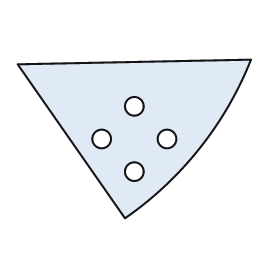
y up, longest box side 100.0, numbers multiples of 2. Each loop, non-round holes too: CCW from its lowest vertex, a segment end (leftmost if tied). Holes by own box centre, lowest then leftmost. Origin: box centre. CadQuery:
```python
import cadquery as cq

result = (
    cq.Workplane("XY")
    .moveTo(-4.0, -34.0)
    .threePointArc((28.0, -4.0), (50.0, 34.0))
    .lineTo(-50.0, 32.0)
    .close()
    .moveTo(0.0, -14.0)
    .circle(4.0)
    .moveTo(-14.0, 0.0)
    .circle(4.0)
    .moveTo(14.0, 0.0)
    .circle(4.0)
    .moveTo(0.0, 14.0)
    .circle(4.0)
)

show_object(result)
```